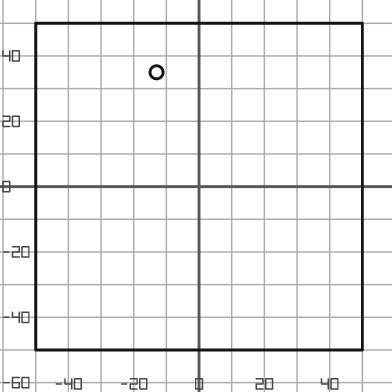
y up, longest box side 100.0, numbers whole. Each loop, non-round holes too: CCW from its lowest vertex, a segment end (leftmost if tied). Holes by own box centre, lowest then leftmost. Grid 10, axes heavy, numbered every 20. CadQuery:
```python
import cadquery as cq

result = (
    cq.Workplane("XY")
    .moveTo(-50.0, -50.0)
    .lineTo(50.0, -50.0)
    .lineTo(50.0, 50.0)
    .lineTo(-50.0, 50.0)
    .close()
    .moveTo(-13.0, 35.0)
    .circle(2.0)
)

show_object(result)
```